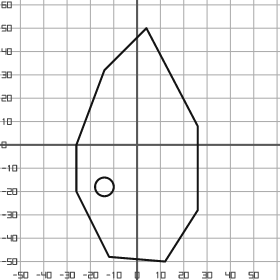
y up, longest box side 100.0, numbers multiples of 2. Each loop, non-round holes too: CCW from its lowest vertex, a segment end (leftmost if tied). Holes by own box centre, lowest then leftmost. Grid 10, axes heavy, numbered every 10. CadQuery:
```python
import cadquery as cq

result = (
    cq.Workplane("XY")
    .moveTo(12.0, -50.0)
    .lineTo(26.0, -28.0)
    .lineTo(26.0, 8.0)
    .lineTo(4.0, 50.0)
    .lineTo(-14.0, 32.0)
    .lineTo(-26.0, 0.0)
    .lineTo(-26.0, -20.0)
    .lineTo(-12.0, -48.0)
    .close()
    .moveTo(-14.0, -18.0)
    .circle(4.0)
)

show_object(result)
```